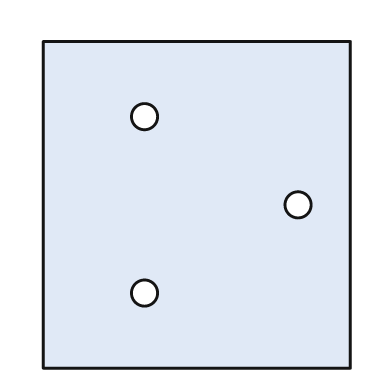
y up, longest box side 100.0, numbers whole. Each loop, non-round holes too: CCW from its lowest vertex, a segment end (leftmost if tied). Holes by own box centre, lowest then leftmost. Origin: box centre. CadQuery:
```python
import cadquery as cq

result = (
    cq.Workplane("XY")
    .moveTo(-47.0, -50.0)
    .lineTo(47.0, -50.0)
    .lineTo(47.0, 50.0)
    .lineTo(-47.0, 50.0)
    .close()
    .moveTo(-16.0, -27.0)
    .circle(4.0)
    .moveTo(31.0, 0.0)
    .circle(4.0)
    .moveTo(-16.0, 27.0)
    .circle(4.0)
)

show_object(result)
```